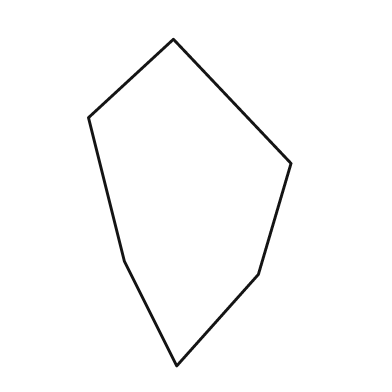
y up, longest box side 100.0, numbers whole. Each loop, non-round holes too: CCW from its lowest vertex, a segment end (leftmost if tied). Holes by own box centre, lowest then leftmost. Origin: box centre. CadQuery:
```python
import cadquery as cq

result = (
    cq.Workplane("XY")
    .moveTo(-4.0, -50.0)
    .lineTo(21.0, -22.0)
    .lineTo(31.0, 12.0)
    .lineTo(-5.0, 50.0)
    .lineTo(-31.0, 26.0)
    .lineTo(-20.0, -18.0)
    .close()
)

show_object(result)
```